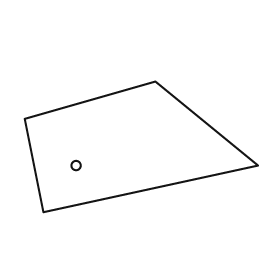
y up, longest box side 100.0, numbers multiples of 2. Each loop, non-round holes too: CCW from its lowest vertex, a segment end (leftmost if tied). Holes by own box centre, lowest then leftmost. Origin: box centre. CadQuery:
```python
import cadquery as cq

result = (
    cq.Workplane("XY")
    .moveTo(-42.0, -28.0)
    .lineTo(50.0, -8.0)
    .lineTo(6.0, 28.0)
    .lineTo(-50.0, 12.0)
    .close()
    .moveTo(-28.0, -8.0)
    .circle(2.0)
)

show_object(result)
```